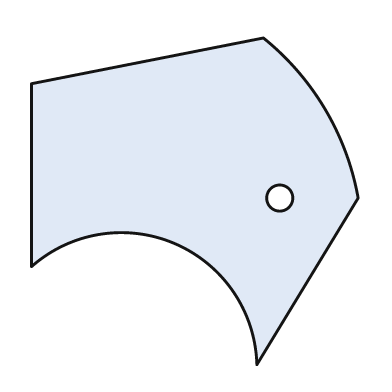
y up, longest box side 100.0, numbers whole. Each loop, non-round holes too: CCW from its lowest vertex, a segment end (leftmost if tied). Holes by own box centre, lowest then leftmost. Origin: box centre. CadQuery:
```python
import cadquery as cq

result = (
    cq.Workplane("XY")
    .moveTo(19.0, -50.0)
    .lineTo(50.0, 1.0)
    .threePointArc((40.0, 28.0), (21.0, 50.0))
    .lineTo(-50.0, 36.0)
    .lineTo(-50.0, -20.0)
    .threePointArc((-6.0, -13.0), (19.0, -50.0))
    .close()
    .moveTo(26.0, 1.0)
    .circle(4.0)
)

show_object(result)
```